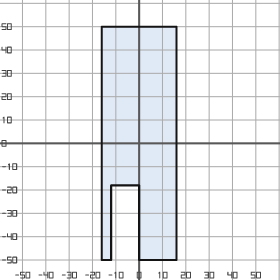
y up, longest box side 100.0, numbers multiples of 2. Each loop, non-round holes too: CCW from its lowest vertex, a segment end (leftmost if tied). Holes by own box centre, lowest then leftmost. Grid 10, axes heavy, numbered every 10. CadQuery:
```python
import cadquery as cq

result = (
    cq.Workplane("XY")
    .moveTo(-16.0, -50.0)
    .lineTo(-12.0, -50.0)
    .lineTo(-12.0, -18.0)
    .lineTo(0.0, -18.0)
    .lineTo(0.0, -50.0)
    .lineTo(16.0, -50.0)
    .lineTo(16.0, 50.0)
    .lineTo(-16.0, 50.0)
    .close()
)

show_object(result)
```